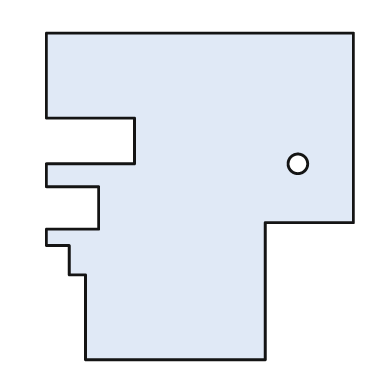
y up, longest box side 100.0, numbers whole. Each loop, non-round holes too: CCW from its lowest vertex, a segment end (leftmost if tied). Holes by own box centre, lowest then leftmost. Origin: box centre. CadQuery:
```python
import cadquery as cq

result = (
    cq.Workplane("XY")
    .moveTo(-35.0, -50.0)
    .lineTo(20.0, -50.0)
    .lineTo(20.0, -8.0)
    .lineTo(47.0, -8.0)
    .lineTo(47.0, 50.0)
    .lineTo(-47.0, 50.0)
    .lineTo(-47.0, 24.0)
    .lineTo(-20.0, 24.0)
    .lineTo(-20.0, 10.0)
    .lineTo(-47.0, 10.0)
    .lineTo(-47.0, 3.0)
    .lineTo(-31.0, 3.0)
    .lineTo(-31.0, -10.0)
    .lineTo(-47.0, -10.0)
    .lineTo(-47.0, -15.0)
    .lineTo(-40.0, -15.0)
    .lineTo(-40.0, -24.0)
    .lineTo(-35.0, -24.0)
    .close()
    .moveTo(30.0, 10.0)
    .circle(3.0)
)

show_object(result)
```